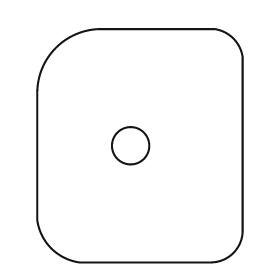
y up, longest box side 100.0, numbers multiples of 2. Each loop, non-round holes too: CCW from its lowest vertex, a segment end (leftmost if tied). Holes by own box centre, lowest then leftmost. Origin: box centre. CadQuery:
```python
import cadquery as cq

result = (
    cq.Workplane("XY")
    .moveTo(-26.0, -50.0)
    .lineTo(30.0, -50.0)
    .threePointArc((40.0, -46.0), (44.0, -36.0))
    .lineTo(44.0, 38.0)
    .threePointArc((40.0, 46.0), (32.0, 50.0))
    .lineTo(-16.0, 50.0)
    .threePointArc((-36.0, 42.0), (-44.0, 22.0))
    .lineTo(-44.0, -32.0)
    .threePointArc((-38.0, -44.0), (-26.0, -50.0))
    .close()
    .moveTo(-4.0, 0.0)
    .circle(8.0)
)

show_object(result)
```